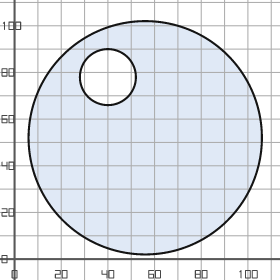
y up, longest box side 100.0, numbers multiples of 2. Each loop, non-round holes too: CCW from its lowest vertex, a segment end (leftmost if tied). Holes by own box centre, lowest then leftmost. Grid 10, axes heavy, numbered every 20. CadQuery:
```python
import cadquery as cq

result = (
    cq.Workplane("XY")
    .moveTo(56.0, 52.0)
    .circle(50.0)
    .moveTo(40.0, 78.0)
    .circle(12.0)
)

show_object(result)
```